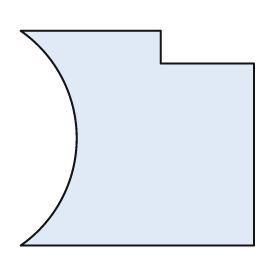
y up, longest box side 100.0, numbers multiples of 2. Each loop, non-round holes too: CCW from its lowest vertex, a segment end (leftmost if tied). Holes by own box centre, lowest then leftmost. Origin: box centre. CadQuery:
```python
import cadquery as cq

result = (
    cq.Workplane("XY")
    .moveTo(-50.0, -46.0)
    .lineTo(50.0, -46.0)
    .lineTo(50.0, 32.0)
    .lineTo(10.0, 32.0)
    .lineTo(10.0, 46.0)
    .lineTo(-50.0, 46.0)
    .threePointArc((-26.0, 0.0), (-50.0, -46.0))
    .close()
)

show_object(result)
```